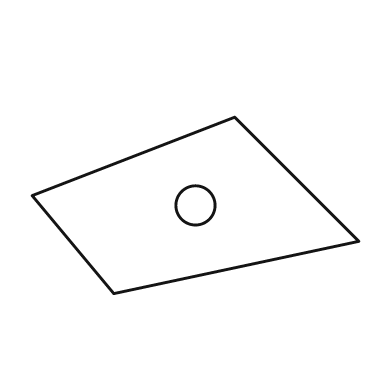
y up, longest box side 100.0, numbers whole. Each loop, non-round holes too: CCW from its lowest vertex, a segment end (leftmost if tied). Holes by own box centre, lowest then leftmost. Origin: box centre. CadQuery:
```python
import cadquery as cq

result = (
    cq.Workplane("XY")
    .moveTo(-25.0, -27.0)
    .lineTo(50.0, -11.0)
    .lineTo(12.0, 27.0)
    .lineTo(-50.0, 3.0)
    .close()
    .moveTo(0.0, 0.0)
    .circle(6.0)
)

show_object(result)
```